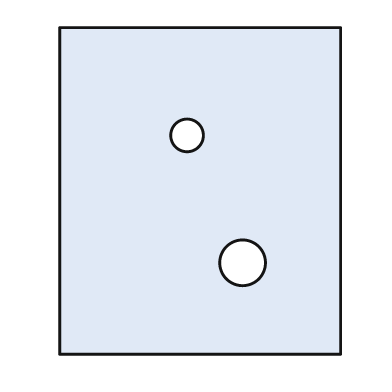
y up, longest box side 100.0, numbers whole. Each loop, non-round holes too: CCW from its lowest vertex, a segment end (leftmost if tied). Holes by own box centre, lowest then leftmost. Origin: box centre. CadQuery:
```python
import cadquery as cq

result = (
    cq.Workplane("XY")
    .moveTo(-43.0, -50.0)
    .lineTo(43.0, -50.0)
    .lineTo(43.0, 50.0)
    .lineTo(-43.0, 50.0)
    .close()
    .moveTo(13.0, -22.0)
    .circle(7.0)
    .moveTo(-4.0, 17.0)
    .circle(5.0)
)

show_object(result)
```